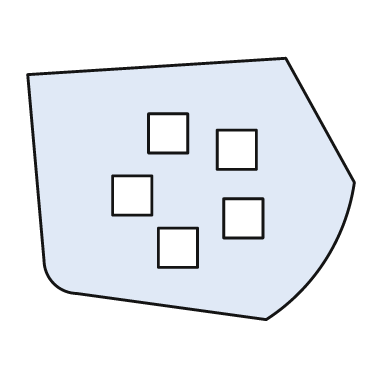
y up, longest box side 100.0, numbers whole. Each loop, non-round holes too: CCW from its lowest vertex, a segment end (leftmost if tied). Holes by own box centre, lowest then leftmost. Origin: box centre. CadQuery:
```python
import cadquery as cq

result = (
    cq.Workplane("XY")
    .moveTo(23.0, -40.0)
    .threePointArc((41.0, -22.0), (50.0, 2.0))
    .lineTo(29.0, 40.0)
    .lineTo(-50.0, 35.0)
    .lineTo(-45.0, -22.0)
    .threePointArc((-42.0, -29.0), (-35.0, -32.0))
    .close()
    .moveTo(-10.0, -24.0)
    .lineTo(2.0, -24.0)
    .lineTo(2.0, -12.0)
    .lineTo(-10.0, -12.0)
    .close()
    .moveTo(10.0, -15.0)
    .lineTo(22.0, -15.0)
    .lineTo(22.0, -3.0)
    .lineTo(10.0, -3.0)
    .close()
    .moveTo(-24.0, -8.0)
    .lineTo(-12.0, -8.0)
    .lineTo(-12.0, 4.0)
    .lineTo(-24.0, 4.0)
    .close()
    .moveTo(8.0, 6.0)
    .lineTo(20.0, 6.0)
    .lineTo(20.0, 18.0)
    .lineTo(8.0, 18.0)
    .close()
    .moveTo(-13.0, 11.0)
    .lineTo(-1.0, 11.0)
    .lineTo(-1.0, 23.0)
    .lineTo(-13.0, 23.0)
    .close()
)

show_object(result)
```